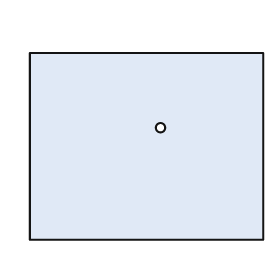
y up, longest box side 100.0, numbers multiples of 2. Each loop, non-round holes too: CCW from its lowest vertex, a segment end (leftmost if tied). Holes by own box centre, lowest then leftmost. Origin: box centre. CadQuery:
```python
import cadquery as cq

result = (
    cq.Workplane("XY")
    .moveTo(-50.0, -40.0)
    .lineTo(50.0, -40.0)
    .lineTo(50.0, 40.0)
    .lineTo(-50.0, 40.0)
    .close()
    .moveTo(6.0, 8.0)
    .circle(2.0)
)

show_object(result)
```